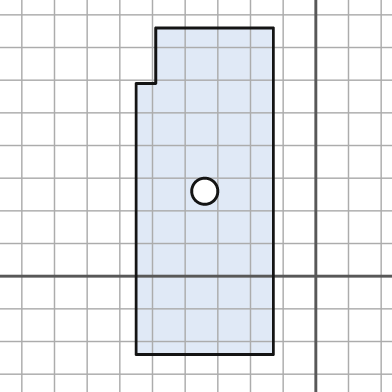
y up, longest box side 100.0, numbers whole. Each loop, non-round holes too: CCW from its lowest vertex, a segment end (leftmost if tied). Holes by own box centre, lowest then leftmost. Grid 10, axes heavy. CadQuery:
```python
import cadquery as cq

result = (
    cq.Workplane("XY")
    .moveTo(-55.0, -24.0)
    .lineTo(-13.0, -24.0)
    .lineTo(-13.0, 76.0)
    .lineTo(-49.0, 76.0)
    .lineTo(-49.0, 59.0)
    .lineTo(-55.0, 59.0)
    .close()
    .moveTo(-34.0, 26.0)
    .circle(4.0)
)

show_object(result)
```